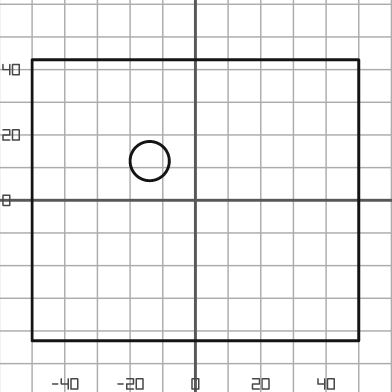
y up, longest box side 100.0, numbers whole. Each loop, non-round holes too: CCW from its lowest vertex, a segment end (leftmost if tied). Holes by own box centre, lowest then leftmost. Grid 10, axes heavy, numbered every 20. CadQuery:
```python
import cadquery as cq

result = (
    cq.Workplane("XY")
    .moveTo(-50.0, -43.0)
    .lineTo(50.0, -43.0)
    .lineTo(50.0, 43.0)
    .lineTo(-50.0, 43.0)
    .close()
    .moveTo(-14.0, 12.0)
    .circle(6.0)
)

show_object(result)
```